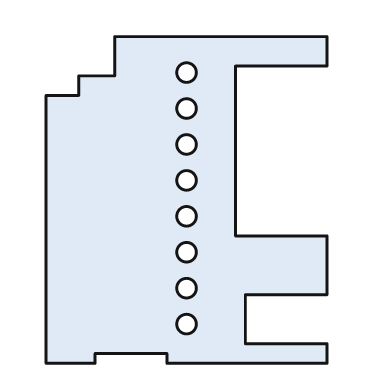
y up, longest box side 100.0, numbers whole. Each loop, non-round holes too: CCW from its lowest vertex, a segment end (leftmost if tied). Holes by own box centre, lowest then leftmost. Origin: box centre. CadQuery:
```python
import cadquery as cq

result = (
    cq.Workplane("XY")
    .moveTo(-43.0, -50.0)
    .lineTo(-28.0, -50.0)
    .lineTo(-28.0, -47.0)
    .lineTo(-6.0, -47.0)
    .lineTo(-6.0, -50.0)
    .lineTo(43.0, -50.0)
    .lineTo(43.0, -44.0)
    .lineTo(18.0, -44.0)
    .lineTo(18.0, -29.0)
    .lineTo(43.0, -29.0)
    .lineTo(43.0, -11.0)
    .lineTo(15.0, -11.0)
    .lineTo(15.0, 41.0)
    .lineTo(43.0, 41.0)
    .lineTo(43.0, 50.0)
    .lineTo(-22.0, 50.0)
    .lineTo(-22.0, 38.0)
    .lineTo(-33.0, 38.0)
    .lineTo(-33.0, 32.0)
    .lineTo(-43.0, 32.0)
    .close()
    .moveTo(0.0, -38.0)
    .circle(3.0)
    .moveTo(0.0, -27.0)
    .circle(3.0)
    .moveTo(0.0, -16.0)
    .circle(3.0)
    .moveTo(0.0, -5.0)
    .circle(3.0)
    .moveTo(0.0, 6.0)
    .circle(3.0)
    .moveTo(0.0, 17.0)
    .circle(3.0)
    .moveTo(0.0, 28.0)
    .circle(3.0)
    .moveTo(0.0, 39.0)
    .circle(3.0)
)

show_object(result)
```